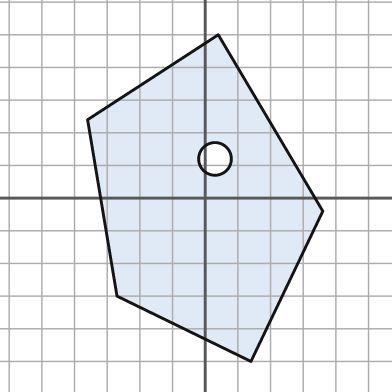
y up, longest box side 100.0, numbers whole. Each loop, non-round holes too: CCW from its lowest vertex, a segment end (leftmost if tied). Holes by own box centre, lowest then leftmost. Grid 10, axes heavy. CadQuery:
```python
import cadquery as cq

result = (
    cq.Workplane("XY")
    .moveTo(14.0, -50.0)
    .lineTo(36.0, -4.0)
    .lineTo(4.0, 50.0)
    .lineTo(-36.0, 24.0)
    .lineTo(-27.0, -30.0)
    .close()
    .moveTo(3.0, 12.0)
    .circle(5.0)
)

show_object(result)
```